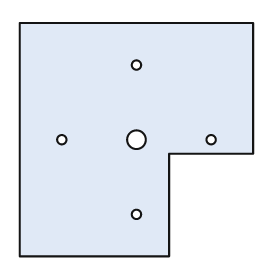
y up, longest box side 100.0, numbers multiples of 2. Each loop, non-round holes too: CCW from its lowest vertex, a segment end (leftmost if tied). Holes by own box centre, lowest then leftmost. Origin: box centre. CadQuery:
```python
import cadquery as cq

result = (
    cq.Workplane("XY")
    .moveTo(-50.0, -50.0)
    .lineTo(14.0, -50.0)
    .lineTo(14.0, -6.0)
    .lineTo(50.0, -6.0)
    .lineTo(50.0, 50.0)
    .lineTo(-50.0, 50.0)
    .close()
    .moveTo(0.0, -32.0)
    .circle(2.0)
    .moveTo(-32.0, 0.0)
    .circle(2.0)
    .moveTo(0.0, 0.0)
    .circle(4.0)
    .moveTo(32.0, 0.0)
    .circle(2.0)
    .moveTo(0.0, 32.0)
    .circle(2.0)
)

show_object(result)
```